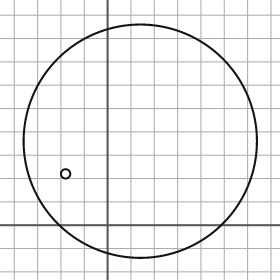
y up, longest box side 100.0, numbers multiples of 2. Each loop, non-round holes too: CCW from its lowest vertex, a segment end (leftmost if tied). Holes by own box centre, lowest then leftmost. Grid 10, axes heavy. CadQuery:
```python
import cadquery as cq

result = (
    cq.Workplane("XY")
    .moveTo(14.0, 36.0)
    .circle(50.0)
    .moveTo(-18.0, 22.0)
    .circle(2.0)
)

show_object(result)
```